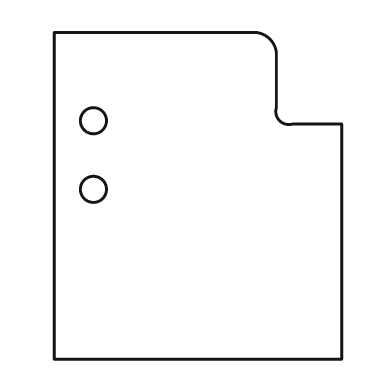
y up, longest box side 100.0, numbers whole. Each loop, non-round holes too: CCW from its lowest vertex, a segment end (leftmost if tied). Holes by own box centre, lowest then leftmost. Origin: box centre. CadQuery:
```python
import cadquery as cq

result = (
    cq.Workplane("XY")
    .moveTo(-44.0, -50.0)
    .lineTo(44.0, -50.0)
    .lineTo(44.0, 22.0)
    .lineTo(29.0, 22.0)
    .threePointArc((25.0, 23.0), (24.0, 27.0))
    .lineTo(24.0, 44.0)
    .threePointArc((22.0, 48.0), (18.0, 50.0))
    .lineTo(-44.0, 50.0)
    .close()
    .moveTo(-32.0, 2.0)
    .circle(4.0)
    .moveTo(-32.0, 23.0)
    .circle(4.0)
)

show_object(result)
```